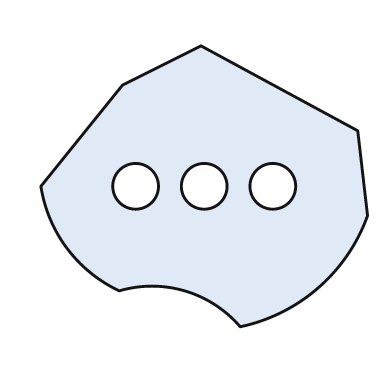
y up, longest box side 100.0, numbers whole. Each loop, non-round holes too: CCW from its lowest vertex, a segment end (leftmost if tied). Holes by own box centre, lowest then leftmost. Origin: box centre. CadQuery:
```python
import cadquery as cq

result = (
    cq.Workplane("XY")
    .moveTo(11.0, -43.0)
    .threePointArc((35.0, -31.0), (50.0, -9.0))
    .lineTo(47.0, 17.0)
    .lineTo(-1.0, 43.0)
    .lineTo(-25.0, 31.0)
    .lineTo(-50.0, 0.0)
    .threePointArc((-42.0, -19.0), (-26.0, -32.0))
    .threePointArc((-6.0, -32.0), (11.0, -43.0))
    .close()
    .moveTo(-21.0, 0.0)
    .circle(7.0)
    .moveTo(0.0, 0.0)
    .circle(7.0)
    .moveTo(21.0, 0.0)
    .circle(7.0)
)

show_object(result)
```